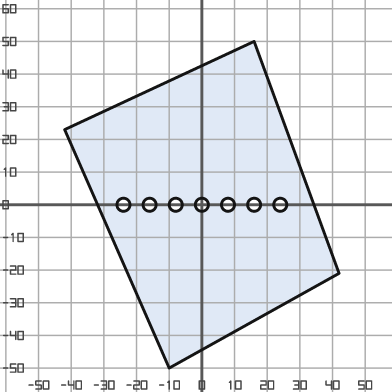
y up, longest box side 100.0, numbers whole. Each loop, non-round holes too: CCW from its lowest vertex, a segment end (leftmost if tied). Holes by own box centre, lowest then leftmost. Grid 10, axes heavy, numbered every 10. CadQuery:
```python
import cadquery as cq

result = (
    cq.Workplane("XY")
    .moveTo(-10.0, -50.0)
    .lineTo(42.0, -21.0)
    .lineTo(16.0, 50.0)
    .lineTo(-42.0, 23.0)
    .close()
    .moveTo(-24.0, 0.0)
    .circle(2.0)
    .moveTo(-16.0, 0.0)
    .circle(2.0)
    .moveTo(-8.0, 0.0)
    .circle(2.0)
    .moveTo(0.0, 0.0)
    .circle(2.0)
    .moveTo(8.0, 0.0)
    .circle(2.0)
    .moveTo(16.0, 0.0)
    .circle(2.0)
    .moveTo(24.0, 0.0)
    .circle(2.0)
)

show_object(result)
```